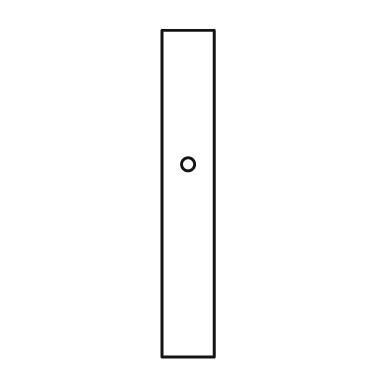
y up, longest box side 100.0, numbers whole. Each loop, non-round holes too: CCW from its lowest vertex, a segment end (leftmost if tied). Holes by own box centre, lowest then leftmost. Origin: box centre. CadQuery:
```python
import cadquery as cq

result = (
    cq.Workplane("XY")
    .moveTo(-8.0, -50.0)
    .lineTo(8.0, -50.0)
    .lineTo(8.0, 50.0)
    .lineTo(-8.0, 50.0)
    .close()
    .moveTo(0.0, 9.0)
    .circle(2.0)
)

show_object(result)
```